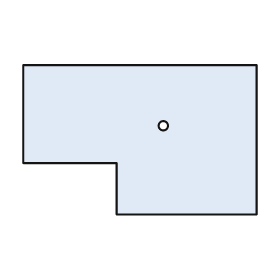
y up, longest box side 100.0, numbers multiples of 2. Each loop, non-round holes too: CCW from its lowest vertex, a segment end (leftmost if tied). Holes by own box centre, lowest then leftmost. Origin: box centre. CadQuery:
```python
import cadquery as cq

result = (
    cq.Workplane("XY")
    .moveTo(-10.0, -32.0)
    .lineTo(50.0, -32.0)
    .lineTo(50.0, 32.0)
    .lineTo(-50.0, 32.0)
    .lineTo(-50.0, -10.0)
    .lineTo(-10.0, -10.0)
    .close()
    .moveTo(10.0, 6.0)
    .circle(2.0)
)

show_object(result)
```